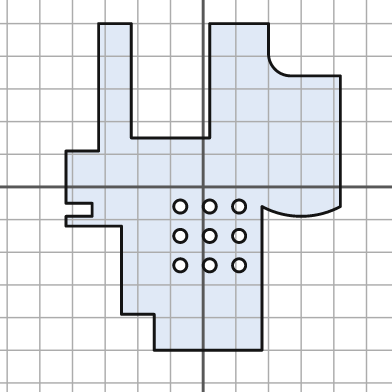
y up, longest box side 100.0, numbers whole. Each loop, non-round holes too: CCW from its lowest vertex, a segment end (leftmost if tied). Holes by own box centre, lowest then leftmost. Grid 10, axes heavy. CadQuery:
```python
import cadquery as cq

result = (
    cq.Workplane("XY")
    .moveTo(-15.0, -50.0)
    .lineTo(18.0, -50.0)
    .lineTo(18.0, -6.0)
    .threePointArc((30.0, -9.0), (42.0, -6.0))
    .lineTo(42.0, 34.0)
    .lineTo(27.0, 34.0)
    .threePointArc((22.0, 36.0), (20.0, 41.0))
    .lineTo(20.0, 50.0)
    .lineTo(2.0, 50.0)
    .lineTo(2.0, 15.0)
    .lineTo(-22.0, 15.0)
    .lineTo(-22.0, 50.0)
    .lineTo(-32.0, 50.0)
    .lineTo(-32.0, 11.0)
    .lineTo(-42.0, 11.0)
    .lineTo(-42.0, -5.0)
    .lineTo(-34.0, -5.0)
    .lineTo(-34.0, -9.0)
    .lineTo(-42.0, -9.0)
    .lineTo(-42.0, -12.0)
    .lineTo(-25.0, -12.0)
    .lineTo(-25.0, -39.0)
    .lineTo(-15.0, -39.0)
    .close()
    .moveTo(-7.0, -24.0)
    .circle(2.0)
    .moveTo(2.0, -24.0)
    .circle(2.0)
    .moveTo(11.0, -24.0)
    .circle(2.0)
    .moveTo(-7.0, -15.0)
    .circle(2.0)
    .moveTo(2.0, -15.0)
    .circle(2.0)
    .moveTo(11.0, -15.0)
    .circle(2.0)
    .moveTo(-7.0, -6.0)
    .circle(2.0)
    .moveTo(2.0, -6.0)
    .circle(2.0)
    .moveTo(11.0, -6.0)
    .circle(2.0)
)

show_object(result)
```